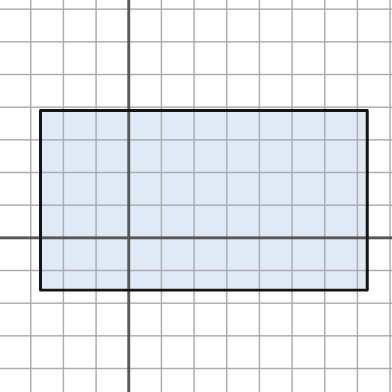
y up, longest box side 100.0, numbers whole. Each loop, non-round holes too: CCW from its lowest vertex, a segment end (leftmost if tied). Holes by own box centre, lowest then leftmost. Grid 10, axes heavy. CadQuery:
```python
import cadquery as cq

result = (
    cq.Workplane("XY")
    .moveTo(-27.0, -16.0)
    .lineTo(73.0, -16.0)
    .lineTo(73.0, 39.0)
    .lineTo(-27.0, 39.0)
    .close()
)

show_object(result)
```